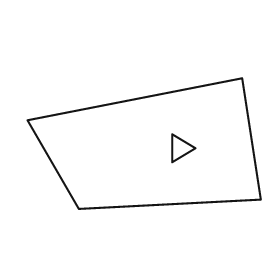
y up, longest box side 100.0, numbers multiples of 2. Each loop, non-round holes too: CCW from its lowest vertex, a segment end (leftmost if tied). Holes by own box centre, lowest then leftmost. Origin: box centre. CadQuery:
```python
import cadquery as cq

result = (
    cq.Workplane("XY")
    .moveTo(-28.0, -28.0)
    .lineTo(50.0, -24.0)
    .lineTo(42.0, 28.0)
    .lineTo(-50.0, 10.0)
    .close()
    .moveTo(12.0, -8.0)
    .lineTo(22.0, -2.0)
    .lineTo(12.0, 4.0)
    .close()
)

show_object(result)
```